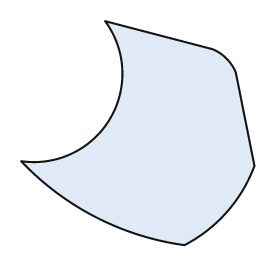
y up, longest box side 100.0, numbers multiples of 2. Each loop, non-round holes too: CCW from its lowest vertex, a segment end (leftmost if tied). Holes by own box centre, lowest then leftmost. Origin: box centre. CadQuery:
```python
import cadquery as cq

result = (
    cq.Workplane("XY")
    .moveTo(20.0, -48.0)
    .threePointArc((38.0, -34.0), (50.0, -14.0))
    .lineTo(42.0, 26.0)
    .threePointArc((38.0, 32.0), (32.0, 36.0))
    .lineTo(-14.0, 48.0)
    .threePointArc((-12.0, 6.0), (-50.0, -12.0))
    .threePointArc((-18.0, -36.0), (20.0, -48.0))
    .close()
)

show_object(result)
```